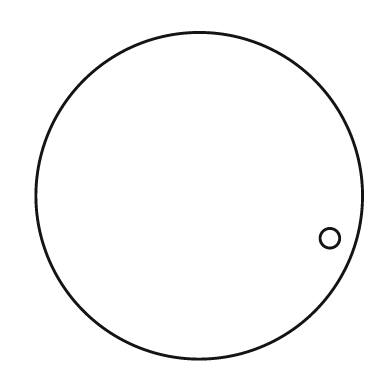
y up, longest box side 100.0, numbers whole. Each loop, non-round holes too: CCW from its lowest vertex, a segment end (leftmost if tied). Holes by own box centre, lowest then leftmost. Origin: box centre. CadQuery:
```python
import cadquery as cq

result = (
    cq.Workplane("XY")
    .moveTo(0.0, 0.0)
    .circle(50.0)
    .moveTo(40.0, -13.0)
    .circle(3.0)
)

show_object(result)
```